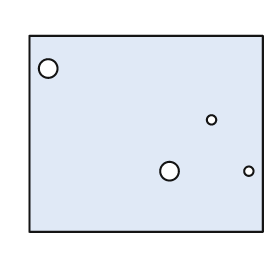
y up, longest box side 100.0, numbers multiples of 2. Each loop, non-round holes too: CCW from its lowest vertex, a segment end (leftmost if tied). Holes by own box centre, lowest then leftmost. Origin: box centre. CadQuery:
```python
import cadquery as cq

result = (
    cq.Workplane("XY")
    .moveTo(-50.0, -42.0)
    .lineTo(50.0, -42.0)
    .lineTo(50.0, 42.0)
    .lineTo(-50.0, 42.0)
    .close()
    .moveTo(10.0, -16.0)
    .circle(4.0)
    .moveTo(44.0, -16.0)
    .circle(2.0)
    .moveTo(28.0, 6.0)
    .circle(2.0)
    .moveTo(-42.0, 28.0)
    .circle(4.0)
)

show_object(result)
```